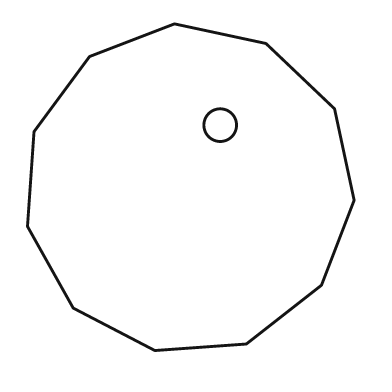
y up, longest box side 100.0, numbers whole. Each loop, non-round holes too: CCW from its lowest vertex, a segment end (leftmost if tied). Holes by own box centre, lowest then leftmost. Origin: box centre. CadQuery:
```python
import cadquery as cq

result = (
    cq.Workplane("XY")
    .moveTo(-11.0, -50.0)
    .lineTo(17.0, -48.0)
    .lineTo(40.0, -30.0)
    .lineTo(50.0, -4.0)
    .lineTo(44.0, 24.0)
    .lineTo(23.0, 44.0)
    .lineTo(-5.0, 50.0)
    .lineTo(-31.0, 40.0)
    .lineTo(-48.0, 17.0)
    .lineTo(-50.0, -12.0)
    .lineTo(-36.0, -37.0)
    .close()
    .moveTo(9.0, 19.0)
    .circle(5.0)
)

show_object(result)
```